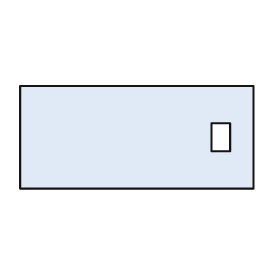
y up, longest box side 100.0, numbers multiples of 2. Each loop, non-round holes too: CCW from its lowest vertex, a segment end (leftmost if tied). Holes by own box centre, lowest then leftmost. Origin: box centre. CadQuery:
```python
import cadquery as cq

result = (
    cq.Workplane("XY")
    .moveTo(-50.0, -22.0)
    .lineTo(50.0, -22.0)
    .lineTo(50.0, 22.0)
    .lineTo(-50.0, 22.0)
    .close()
    .moveTo(32.0, -6.0)
    .lineTo(40.0, -6.0)
    .lineTo(40.0, 6.0)
    .lineTo(32.0, 6.0)
    .close()
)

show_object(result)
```